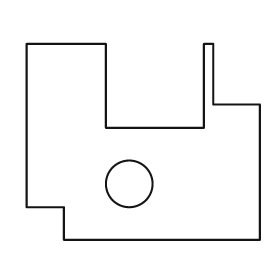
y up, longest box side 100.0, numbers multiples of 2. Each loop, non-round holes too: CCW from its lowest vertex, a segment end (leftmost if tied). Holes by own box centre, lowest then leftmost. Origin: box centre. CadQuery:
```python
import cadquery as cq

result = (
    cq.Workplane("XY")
    .moveTo(-34.0, -42.0)
    .lineTo(50.0, -42.0)
    .lineTo(50.0, 16.0)
    .lineTo(30.0, 16.0)
    .lineTo(30.0, 42.0)
    .lineTo(26.0, 42.0)
    .lineTo(26.0, 6.0)
    .lineTo(-16.0, 6.0)
    .lineTo(-16.0, 42.0)
    .lineTo(-50.0, 42.0)
    .lineTo(-50.0, -28.0)
    .lineTo(-34.0, -28.0)
    .close()
    .moveTo(-6.0, -18.0)
    .circle(10.0)
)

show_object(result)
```